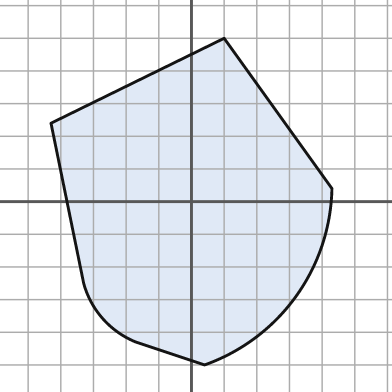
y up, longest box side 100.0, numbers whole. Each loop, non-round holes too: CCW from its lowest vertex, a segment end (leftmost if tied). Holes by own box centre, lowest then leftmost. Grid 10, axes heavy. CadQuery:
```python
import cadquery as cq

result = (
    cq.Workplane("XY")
    .moveTo(4.0, -50.0)
    .threePointArc((32.0, -29.0), (43.0, 4.0))
    .lineTo(10.0, 50.0)
    .lineTo(-43.0, 24.0)
    .lineTo(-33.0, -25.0)
    .threePointArc((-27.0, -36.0), (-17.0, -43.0))
    .close()
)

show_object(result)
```